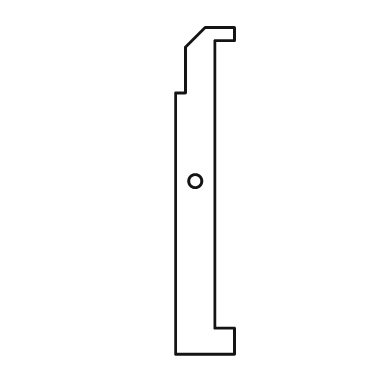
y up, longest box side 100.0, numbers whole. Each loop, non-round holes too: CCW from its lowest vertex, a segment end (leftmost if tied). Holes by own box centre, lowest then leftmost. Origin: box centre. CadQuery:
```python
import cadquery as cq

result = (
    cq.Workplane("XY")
    .moveTo(-9.0, -50.0)
    .lineTo(9.0, -50.0)
    .lineTo(9.0, -42.0)
    .lineTo(3.0, -42.0)
    .lineTo(3.0, 46.0)
    .lineTo(9.0, 46.0)
    .lineTo(9.0, 50.0)
    .lineTo(0.0, 50.0)
    .lineTo(-6.0, 44.0)
    .lineTo(-6.0, 30.0)
    .lineTo(-9.0, 30.0)
    .close()
    .moveTo(-3.0, 3.0)
    .circle(2.0)
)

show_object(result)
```